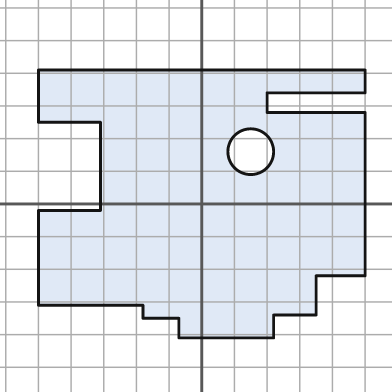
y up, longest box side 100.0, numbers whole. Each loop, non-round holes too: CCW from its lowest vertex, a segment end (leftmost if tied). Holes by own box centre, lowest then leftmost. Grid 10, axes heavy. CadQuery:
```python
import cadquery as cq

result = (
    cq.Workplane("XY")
    .moveTo(-7.0, -41.0)
    .lineTo(22.0, -41.0)
    .lineTo(22.0, -34.0)
    .lineTo(35.0, -34.0)
    .lineTo(35.0, -22.0)
    .lineTo(50.0, -22.0)
    .lineTo(50.0, 28.0)
    .lineTo(20.0, 28.0)
    .lineTo(20.0, 34.0)
    .lineTo(50.0, 34.0)
    .lineTo(50.0, 41.0)
    .lineTo(-50.0, 41.0)
    .lineTo(-50.0, 25.0)
    .lineTo(-31.0, 25.0)
    .lineTo(-31.0, -2.0)
    .lineTo(-50.0, -2.0)
    .lineTo(-50.0, -31.0)
    .lineTo(-18.0, -31.0)
    .lineTo(-18.0, -35.0)
    .lineTo(-7.0, -35.0)
    .close()
    .moveTo(15.0, 16.0)
    .circle(7.0)
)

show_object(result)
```